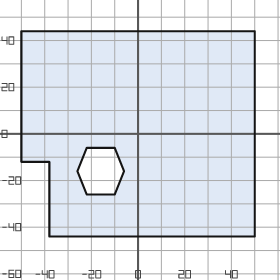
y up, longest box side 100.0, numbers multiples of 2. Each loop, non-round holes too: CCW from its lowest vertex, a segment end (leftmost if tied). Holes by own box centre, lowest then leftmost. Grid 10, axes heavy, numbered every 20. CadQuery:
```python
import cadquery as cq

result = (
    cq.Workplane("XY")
    .moveTo(-38.0, -44.0)
    .lineTo(50.0, -44.0)
    .lineTo(50.0, 44.0)
    .lineTo(-50.0, 44.0)
    .lineTo(-50.0, -12.0)
    .lineTo(-38.0, -12.0)
    .close()
    .moveTo(-22.0, -26.0)
    .lineTo(-10.0, -26.0)
    .lineTo(-6.0, -16.0)
    .lineTo(-10.0, -6.0)
    .lineTo(-22.0, -6.0)
    .lineTo(-26.0, -16.0)
    .close()
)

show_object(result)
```